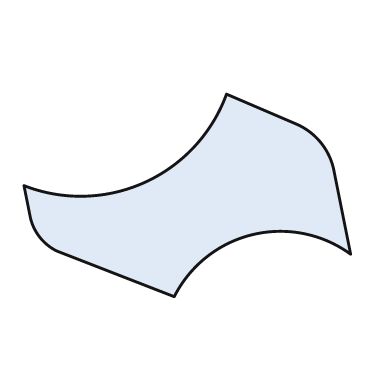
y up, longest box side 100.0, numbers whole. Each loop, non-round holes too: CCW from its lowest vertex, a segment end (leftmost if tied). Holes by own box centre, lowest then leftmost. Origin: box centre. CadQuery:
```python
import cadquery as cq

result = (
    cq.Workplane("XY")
    .moveTo(-4.0, -31.0)
    .threePointArc((20.0, -12.0), (50.0, -18.0))
    .lineTo(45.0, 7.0)
    .threePointArc((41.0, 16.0), (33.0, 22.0))
    .lineTo(12.0, 31.0)
    .threePointArc((-13.0, 4.0), (-50.0, 3.0))
    .lineTo(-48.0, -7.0)
    .threePointArc((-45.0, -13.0), (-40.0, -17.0))
    .close()
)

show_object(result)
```